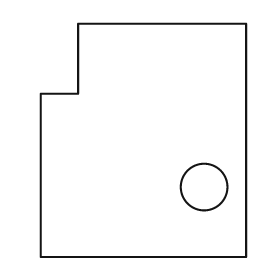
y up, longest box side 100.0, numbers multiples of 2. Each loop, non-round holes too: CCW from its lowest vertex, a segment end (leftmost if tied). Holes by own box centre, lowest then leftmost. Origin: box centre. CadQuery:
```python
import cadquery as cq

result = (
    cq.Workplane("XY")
    .moveTo(-44.0, -50.0)
    .lineTo(44.0, -50.0)
    .lineTo(44.0, 50.0)
    .lineTo(-28.0, 50.0)
    .lineTo(-28.0, 20.0)
    .lineTo(-44.0, 20.0)
    .close()
    .moveTo(26.0, -20.0)
    .circle(10.0)
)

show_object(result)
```